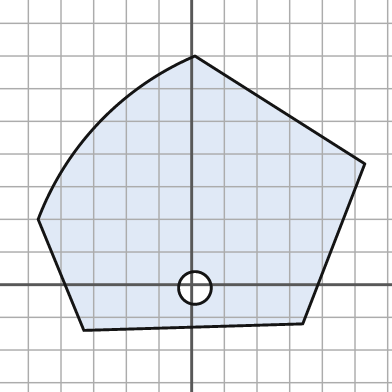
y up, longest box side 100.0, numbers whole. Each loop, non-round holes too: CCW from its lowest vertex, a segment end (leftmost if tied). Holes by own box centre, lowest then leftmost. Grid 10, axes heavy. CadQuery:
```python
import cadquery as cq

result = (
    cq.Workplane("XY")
    .moveTo(-33.0, -14.0)
    .lineTo(34.0, -12.0)
    .lineTo(53.0, 37.0)
    .lineTo(1.0, 70.0)
    .threePointArc((-28.0, 50.0), (-47.0, 20.0))
    .close()
    .moveTo(1.0, -1.0)
    .circle(5.0)
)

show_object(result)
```